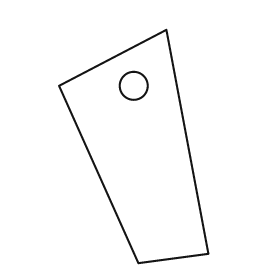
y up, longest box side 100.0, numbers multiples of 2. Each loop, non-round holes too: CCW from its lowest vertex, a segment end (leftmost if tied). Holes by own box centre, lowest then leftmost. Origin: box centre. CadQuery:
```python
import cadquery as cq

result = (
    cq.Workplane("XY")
    .moveTo(2.0, -50.0)
    .lineTo(32.0, -46.0)
    .lineTo(14.0, 50.0)
    .lineTo(-32.0, 26.0)
    .close()
    .moveTo(0.0, 26.0)
    .circle(6.0)
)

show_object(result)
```